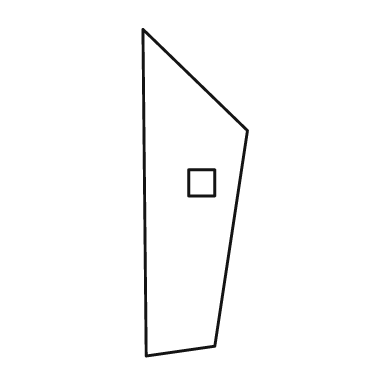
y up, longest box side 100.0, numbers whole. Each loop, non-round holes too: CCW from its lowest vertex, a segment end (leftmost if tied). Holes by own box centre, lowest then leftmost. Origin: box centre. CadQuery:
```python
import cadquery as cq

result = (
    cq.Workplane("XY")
    .moveTo(-15.0, -50.0)
    .lineTo(6.0, -47.0)
    .lineTo(16.0, 19.0)
    .lineTo(-16.0, 50.0)
    .close()
    .moveTo(-2.0, -1.0)
    .lineTo(6.0, -1.0)
    .lineTo(6.0, 7.0)
    .lineTo(-2.0, 7.0)
    .close()
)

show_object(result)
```